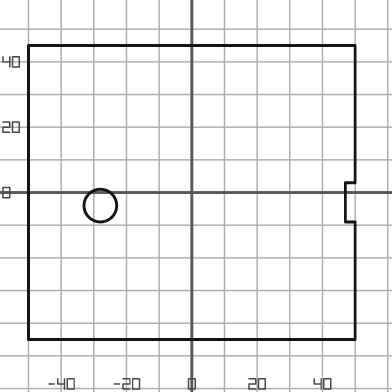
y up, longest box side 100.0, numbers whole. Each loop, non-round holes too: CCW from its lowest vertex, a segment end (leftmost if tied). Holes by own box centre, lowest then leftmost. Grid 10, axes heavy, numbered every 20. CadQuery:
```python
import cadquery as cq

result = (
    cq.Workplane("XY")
    .moveTo(-50.0, -45.0)
    .lineTo(50.0, -45.0)
    .lineTo(50.0, -9.0)
    .lineTo(47.0, -9.0)
    .lineTo(47.0, 3.0)
    .lineTo(50.0, 3.0)
    .lineTo(50.0, 45.0)
    .lineTo(-50.0, 45.0)
    .close()
    .moveTo(-28.0, -4.0)
    .circle(5.0)
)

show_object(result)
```